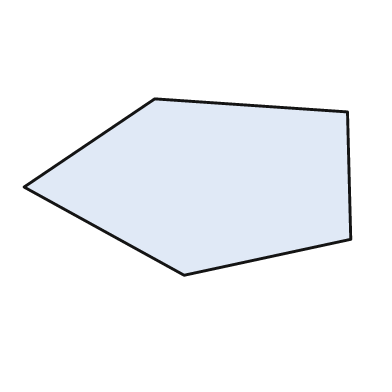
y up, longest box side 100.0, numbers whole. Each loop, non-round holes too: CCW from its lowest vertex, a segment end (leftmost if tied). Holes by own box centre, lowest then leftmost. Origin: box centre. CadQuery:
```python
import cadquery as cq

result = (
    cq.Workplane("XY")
    .moveTo(-1.0, -27.0)
    .lineTo(50.0, -16.0)
    .lineTo(49.0, 23.0)
    .lineTo(-10.0, 27.0)
    .lineTo(-50.0, 0.0)
    .close()
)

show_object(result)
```